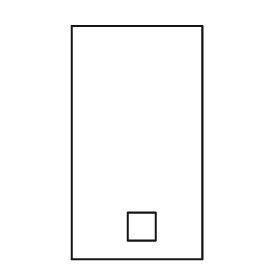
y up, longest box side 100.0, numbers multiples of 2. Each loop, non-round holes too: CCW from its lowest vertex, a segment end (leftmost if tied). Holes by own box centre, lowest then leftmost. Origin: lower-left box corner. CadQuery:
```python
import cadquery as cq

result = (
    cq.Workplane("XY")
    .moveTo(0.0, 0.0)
    .lineTo(56.0, 0.0)
    .lineTo(56.0, 100.0)
    .lineTo(0.0, 100.0)
    .close()
    .moveTo(24.0, 8.0)
    .lineTo(36.0, 8.0)
    .lineTo(36.0, 20.0)
    .lineTo(24.0, 20.0)
    .close()
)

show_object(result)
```